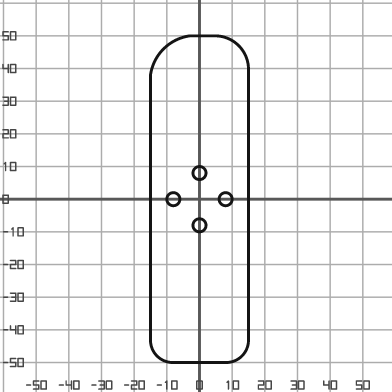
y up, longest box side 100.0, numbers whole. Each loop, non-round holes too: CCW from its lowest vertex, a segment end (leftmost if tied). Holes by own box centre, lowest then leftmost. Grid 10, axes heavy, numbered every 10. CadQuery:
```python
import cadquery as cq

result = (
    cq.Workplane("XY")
    .moveTo(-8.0, -50.0)
    .lineTo(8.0, -50.0)
    .threePointArc((13.0, -48.0), (15.0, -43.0))
    .lineTo(15.0, 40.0)
    .threePointArc((12.0, 47.0), (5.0, 50.0))
    .lineTo(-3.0, 50.0)
    .threePointArc((-11.0, 46.0), (-15.0, 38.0))
    .lineTo(-15.0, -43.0)
    .threePointArc((-13.0, -48.0), (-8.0, -50.0))
    .close()
    .moveTo(0.0, -8.0)
    .circle(2.0)
    .moveTo(-8.0, 0.0)
    .circle(2.0)
    .moveTo(8.0, 0.0)
    .circle(2.0)
    .moveTo(0.0, 8.0)
    .circle(2.0)
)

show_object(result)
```